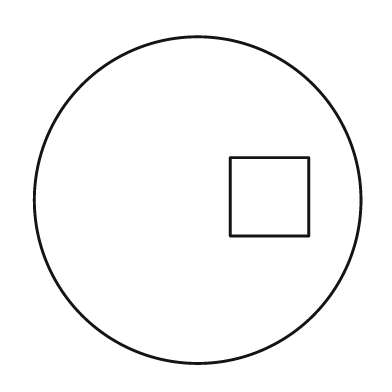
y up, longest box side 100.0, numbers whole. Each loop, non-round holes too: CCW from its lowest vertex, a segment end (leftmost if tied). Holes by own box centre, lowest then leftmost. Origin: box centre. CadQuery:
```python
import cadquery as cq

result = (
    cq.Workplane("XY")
    .moveTo(0.0, 0.0)
    .circle(50.0)
    .moveTo(10.0, -11.0)
    .lineTo(34.0, -11.0)
    .lineTo(34.0, 13.0)
    .lineTo(10.0, 13.0)
    .close()
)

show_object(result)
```